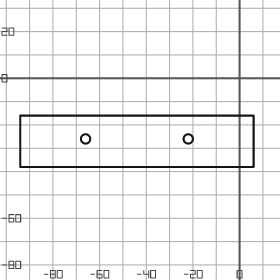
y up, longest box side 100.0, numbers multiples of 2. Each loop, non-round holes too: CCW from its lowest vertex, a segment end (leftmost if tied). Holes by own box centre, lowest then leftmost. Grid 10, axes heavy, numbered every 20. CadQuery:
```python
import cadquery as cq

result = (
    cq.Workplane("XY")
    .moveTo(-94.0, -38.0)
    .lineTo(6.0, -38.0)
    .lineTo(6.0, -16.0)
    .lineTo(-94.0, -16.0)
    .close()
    .moveTo(-66.0, -26.0)
    .circle(2.0)
    .moveTo(-22.0, -26.0)
    .circle(2.0)
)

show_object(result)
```